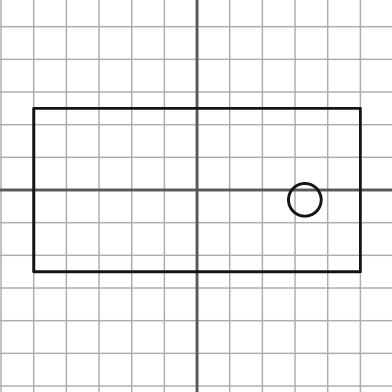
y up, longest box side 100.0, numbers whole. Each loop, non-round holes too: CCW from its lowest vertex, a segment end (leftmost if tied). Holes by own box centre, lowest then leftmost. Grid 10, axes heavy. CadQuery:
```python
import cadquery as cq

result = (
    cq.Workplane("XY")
    .moveTo(-50.0, -25.0)
    .lineTo(50.0, -25.0)
    .lineTo(50.0, 25.0)
    .lineTo(-50.0, 25.0)
    .close()
    .moveTo(33.0, -3.0)
    .circle(5.0)
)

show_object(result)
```